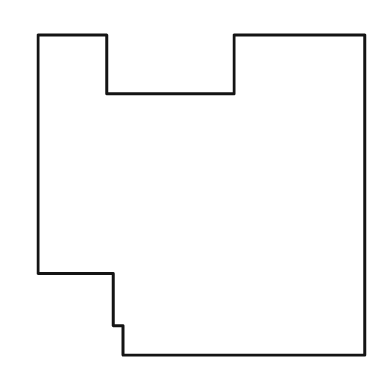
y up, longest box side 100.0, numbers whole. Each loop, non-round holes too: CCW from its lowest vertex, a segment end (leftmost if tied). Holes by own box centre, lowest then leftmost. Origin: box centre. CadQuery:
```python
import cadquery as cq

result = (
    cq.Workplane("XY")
    .moveTo(-24.0, -49.0)
    .lineTo(50.0, -49.0)
    .lineTo(50.0, 49.0)
    .lineTo(10.0, 49.0)
    .lineTo(10.0, 31.0)
    .lineTo(-29.0, 31.0)
    .lineTo(-29.0, 49.0)
    .lineTo(-50.0, 49.0)
    .lineTo(-50.0, -24.0)
    .lineTo(-27.0, -24.0)
    .lineTo(-27.0, -40.0)
    .lineTo(-24.0, -40.0)
    .close()
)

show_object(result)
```